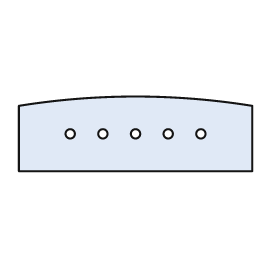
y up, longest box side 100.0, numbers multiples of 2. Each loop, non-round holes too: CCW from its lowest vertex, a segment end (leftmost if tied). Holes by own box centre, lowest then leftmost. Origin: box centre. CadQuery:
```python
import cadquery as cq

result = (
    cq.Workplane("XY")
    .moveTo(-50.0, -16.0)
    .lineTo(50.0, -16.0)
    .lineTo(50.0, 12.0)
    .threePointArc((0.0, 16.0), (-50.0, 12.0))
    .close()
    .moveTo(-28.0, 0.0)
    .circle(2.0)
    .moveTo(-14.0, 0.0)
    .circle(2.0)
    .moveTo(0.0, 0.0)
    .circle(2.0)
    .moveTo(14.0, 0.0)
    .circle(2.0)
    .moveTo(28.0, 0.0)
    .circle(2.0)
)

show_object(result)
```